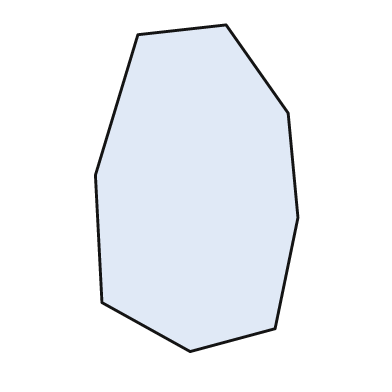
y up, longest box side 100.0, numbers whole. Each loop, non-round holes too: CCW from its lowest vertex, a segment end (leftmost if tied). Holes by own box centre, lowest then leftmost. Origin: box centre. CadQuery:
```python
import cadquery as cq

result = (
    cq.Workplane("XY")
    .moveTo(-2.0, -50.0)
    .lineTo(24.0, -43.0)
    .lineTo(31.0, -9.0)
    .lineTo(28.0, 23.0)
    .lineTo(9.0, 50.0)
    .lineTo(-18.0, 47.0)
    .lineTo(-31.0, 4.0)
    .lineTo(-29.0, -35.0)
    .close()
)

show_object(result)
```